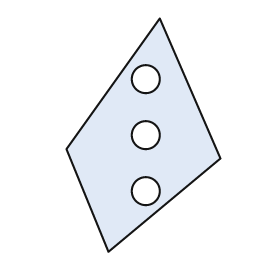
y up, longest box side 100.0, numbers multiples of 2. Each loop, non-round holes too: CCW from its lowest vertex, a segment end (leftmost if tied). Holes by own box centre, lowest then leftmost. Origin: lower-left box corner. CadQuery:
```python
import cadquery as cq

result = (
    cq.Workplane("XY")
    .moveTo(18.0, 0.0)
    .lineTo(66.0, 40.0)
    .lineTo(40.0, 100.0)
    .lineTo(0.0, 44.0)
    .close()
    .moveTo(34.0, 26.0)
    .circle(6.0)
    .moveTo(34.0, 50.0)
    .circle(6.0)
    .moveTo(34.0, 74.0)
    .circle(6.0)
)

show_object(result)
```